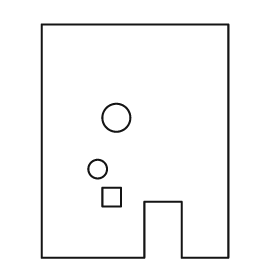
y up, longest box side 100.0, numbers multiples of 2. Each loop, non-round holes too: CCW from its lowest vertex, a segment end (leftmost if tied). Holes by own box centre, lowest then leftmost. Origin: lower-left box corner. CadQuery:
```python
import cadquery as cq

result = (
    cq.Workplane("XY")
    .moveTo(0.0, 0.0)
    .lineTo(44.0, 0.0)
    .lineTo(44.0, 24.0)
    .lineTo(60.0, 24.0)
    .lineTo(60.0, 0.0)
    .lineTo(80.0, 0.0)
    .lineTo(80.0, 100.0)
    .lineTo(0.0, 100.0)
    .close()
    .moveTo(26.0, 22.0)
    .lineTo(34.0, 22.0)
    .lineTo(34.0, 30.0)
    .lineTo(26.0, 30.0)
    .close()
    .moveTo(24.0, 38.0)
    .circle(4.0)
    .moveTo(32.0, 60.0)
    .circle(6.0)
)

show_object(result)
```